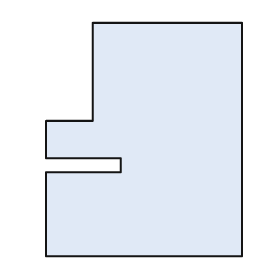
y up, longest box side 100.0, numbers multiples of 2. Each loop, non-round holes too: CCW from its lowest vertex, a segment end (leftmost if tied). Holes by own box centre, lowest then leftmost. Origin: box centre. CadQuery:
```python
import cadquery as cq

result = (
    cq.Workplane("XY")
    .moveTo(-42.0, -50.0)
    .lineTo(42.0, -50.0)
    .lineTo(42.0, 50.0)
    .lineTo(-22.0, 50.0)
    .lineTo(-22.0, 8.0)
    .lineTo(-42.0, 8.0)
    .lineTo(-42.0, -8.0)
    .lineTo(-10.0, -8.0)
    .lineTo(-10.0, -14.0)
    .lineTo(-42.0, -14.0)
    .close()
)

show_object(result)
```